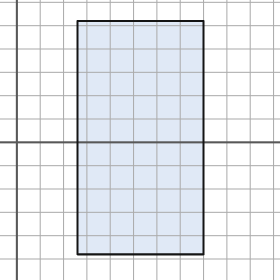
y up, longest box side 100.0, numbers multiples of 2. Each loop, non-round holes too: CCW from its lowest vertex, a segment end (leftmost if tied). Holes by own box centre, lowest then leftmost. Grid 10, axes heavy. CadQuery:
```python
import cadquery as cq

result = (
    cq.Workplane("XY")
    .moveTo(26.0, -48.0)
    .lineTo(80.0, -48.0)
    .lineTo(80.0, 52.0)
    .lineTo(26.0, 52.0)
    .close()
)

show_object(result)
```